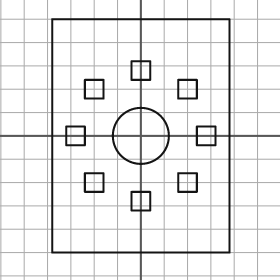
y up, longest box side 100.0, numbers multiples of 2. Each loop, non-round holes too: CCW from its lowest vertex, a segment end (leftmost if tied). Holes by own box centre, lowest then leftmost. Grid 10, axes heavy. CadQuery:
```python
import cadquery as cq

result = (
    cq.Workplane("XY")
    .moveTo(-38.0, -50.0)
    .lineTo(38.0, -50.0)
    .lineTo(38.0, 50.0)
    .lineTo(-38.0, 50.0)
    .close()
    .moveTo(-4.0, -32.0)
    .lineTo(4.0, -32.0)
    .lineTo(4.0, -24.0)
    .lineTo(-4.0, -24.0)
    .close()
    .moveTo(-24.0, -24.0)
    .lineTo(-16.0, -24.0)
    .lineTo(-16.0, -16.0)
    .lineTo(-24.0, -16.0)
    .close()
    .moveTo(16.0, -24.0)
    .lineTo(24.0, -24.0)
    .lineTo(24.0, -16.0)
    .lineTo(16.0, -16.0)
    .close()
    .moveTo(-32.0, -4.0)
    .lineTo(-24.0, -4.0)
    .lineTo(-24.0, 4.0)
    .lineTo(-32.0, 4.0)
    .close()
    .moveTo(0.0, 0.0)
    .circle(12.0)
    .moveTo(24.0, -4.0)
    .lineTo(32.0, -4.0)
    .lineTo(32.0, 4.0)
    .lineTo(24.0, 4.0)
    .close()
    .moveTo(-24.0, 16.0)
    .lineTo(-16.0, 16.0)
    .lineTo(-16.0, 24.0)
    .lineTo(-24.0, 24.0)
    .close()
    .moveTo(16.0, 16.0)
    .lineTo(24.0, 16.0)
    .lineTo(24.0, 24.0)
    .lineTo(16.0, 24.0)
    .close()
    .moveTo(-4.0, 24.0)
    .lineTo(4.0, 24.0)
    .lineTo(4.0, 32.0)
    .lineTo(-4.0, 32.0)
    .close()
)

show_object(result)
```